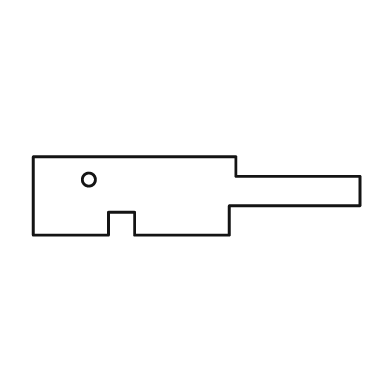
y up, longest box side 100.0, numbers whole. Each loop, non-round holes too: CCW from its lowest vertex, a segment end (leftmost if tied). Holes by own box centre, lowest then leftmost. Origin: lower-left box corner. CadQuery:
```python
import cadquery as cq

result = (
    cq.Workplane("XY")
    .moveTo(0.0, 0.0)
    .lineTo(23.0, 0.0)
    .lineTo(23.0, 7.0)
    .lineTo(31.0, 7.0)
    .lineTo(31.0, 0.0)
    .lineTo(60.0, 0.0)
    .lineTo(60.0, 9.0)
    .lineTo(100.0, 9.0)
    .lineTo(100.0, 18.0)
    .lineTo(62.0, 18.0)
    .lineTo(62.0, 24.0)
    .lineTo(0.0, 24.0)
    .close()
    .moveTo(17.0, 17.0)
    .circle(2.0)
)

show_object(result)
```